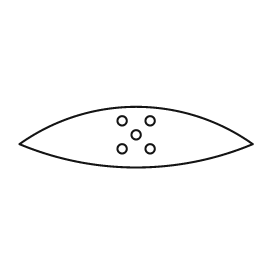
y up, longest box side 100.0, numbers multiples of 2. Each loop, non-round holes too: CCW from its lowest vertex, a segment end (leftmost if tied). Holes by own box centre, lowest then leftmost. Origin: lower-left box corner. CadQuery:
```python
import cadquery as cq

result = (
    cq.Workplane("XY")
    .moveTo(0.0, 10.0)
    .threePointArc((50.0, 0.0), (100.0, 10.0))
    .threePointArc((50.0, 26.0), (0.0, 10.0))
    .close()
    .moveTo(44.0, 8.0)
    .circle(2.0)
    .moveTo(56.0, 8.0)
    .circle(2.0)
    .moveTo(50.0, 14.0)
    .circle(2.0)
    .moveTo(44.0, 20.0)
    .circle(2.0)
    .moveTo(56.0, 20.0)
    .circle(2.0)
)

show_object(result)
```